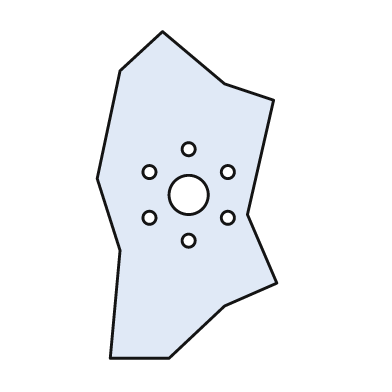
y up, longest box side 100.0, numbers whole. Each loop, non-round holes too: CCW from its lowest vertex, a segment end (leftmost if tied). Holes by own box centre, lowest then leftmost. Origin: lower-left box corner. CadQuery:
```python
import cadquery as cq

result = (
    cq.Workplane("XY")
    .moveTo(4.0, 0.0)
    .lineTo(22.0, 0.0)
    .lineTo(39.0, 16.0)
    .lineTo(55.0, 23.0)
    .lineTo(46.0, 44.0)
    .lineTo(54.0, 79.0)
    .lineTo(39.0, 84.0)
    .lineTo(20.0, 100.0)
    .lineTo(7.0, 88.0)
    .lineTo(0.0, 55.0)
    .lineTo(7.0, 33.0)
    .close()
    .moveTo(28.0, 36.0)
    .circle(2.0)
    .moveTo(16.0, 43.0)
    .circle(2.0)
    .moveTo(40.0, 43.0)
    .circle(2.0)
    .moveTo(28.0, 50.0)
    .circle(6.0)
    .moveTo(16.0, 57.0)
    .circle(2.0)
    .moveTo(40.0, 57.0)
    .circle(2.0)
    .moveTo(28.0, 64.0)
    .circle(2.0)
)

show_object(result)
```